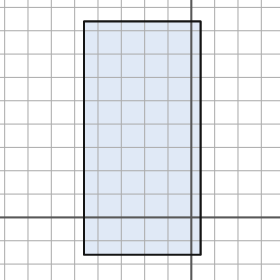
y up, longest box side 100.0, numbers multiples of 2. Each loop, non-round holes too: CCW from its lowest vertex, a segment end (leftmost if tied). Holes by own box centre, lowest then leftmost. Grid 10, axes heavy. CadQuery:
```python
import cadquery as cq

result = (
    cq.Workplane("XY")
    .moveTo(-46.0, -16.0)
    .lineTo(4.0, -16.0)
    .lineTo(4.0, 84.0)
    .lineTo(-46.0, 84.0)
    .close()
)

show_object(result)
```